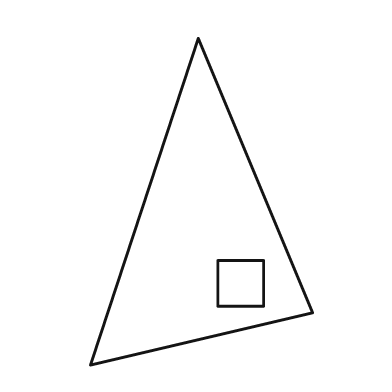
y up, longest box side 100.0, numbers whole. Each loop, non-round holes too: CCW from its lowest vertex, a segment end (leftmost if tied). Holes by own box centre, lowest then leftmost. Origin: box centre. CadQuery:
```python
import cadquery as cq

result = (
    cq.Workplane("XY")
    .moveTo(-34.0, -50.0)
    .lineTo(34.0, -34.0)
    .lineTo(-1.0, 50.0)
    .close()
    .moveTo(5.0, -32.0)
    .lineTo(19.0, -32.0)
    .lineTo(19.0, -18.0)
    .lineTo(5.0, -18.0)
    .close()
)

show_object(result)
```